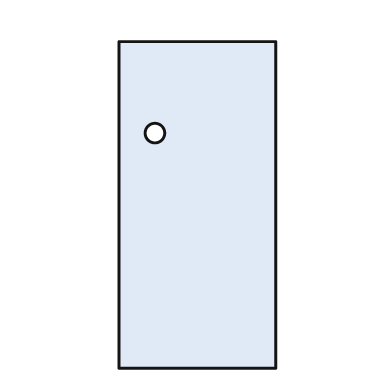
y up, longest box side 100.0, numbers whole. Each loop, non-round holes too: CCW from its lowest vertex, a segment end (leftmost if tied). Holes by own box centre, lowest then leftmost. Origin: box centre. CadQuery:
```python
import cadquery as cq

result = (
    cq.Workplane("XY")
    .moveTo(-24.0, -50.0)
    .lineTo(24.0, -50.0)
    .lineTo(24.0, 50.0)
    .lineTo(-24.0, 50.0)
    .close()
    .moveTo(-13.0, 22.0)
    .circle(3.0)
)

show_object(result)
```